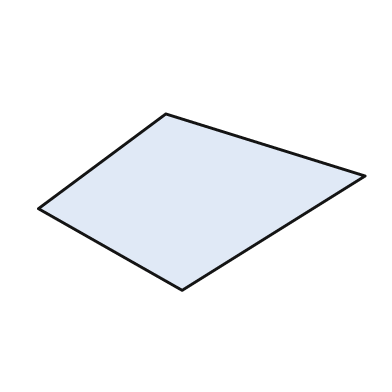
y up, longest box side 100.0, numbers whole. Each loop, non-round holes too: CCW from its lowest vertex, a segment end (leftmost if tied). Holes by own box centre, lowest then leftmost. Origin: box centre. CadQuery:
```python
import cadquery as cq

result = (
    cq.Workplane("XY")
    .moveTo(-6.0, -27.0)
    .lineTo(50.0, 8.0)
    .lineTo(-11.0, 27.0)
    .lineTo(-50.0, -2.0)
    .close()
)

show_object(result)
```